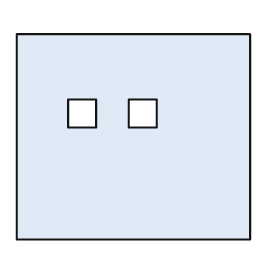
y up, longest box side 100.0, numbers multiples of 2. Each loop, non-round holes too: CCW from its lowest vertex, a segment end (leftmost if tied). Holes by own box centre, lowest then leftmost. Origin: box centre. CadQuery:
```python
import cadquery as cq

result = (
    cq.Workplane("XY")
    .moveTo(-50.0, -44.0)
    .lineTo(50.0, -44.0)
    .lineTo(50.0, 44.0)
    .lineTo(-50.0, 44.0)
    .close()
    .moveTo(-28.0, 4.0)
    .lineTo(-16.0, 4.0)
    .lineTo(-16.0, 16.0)
    .lineTo(-28.0, 16.0)
    .close()
    .moveTo(-2.0, 4.0)
    .lineTo(10.0, 4.0)
    .lineTo(10.0, 16.0)
    .lineTo(-2.0, 16.0)
    .close()
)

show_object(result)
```